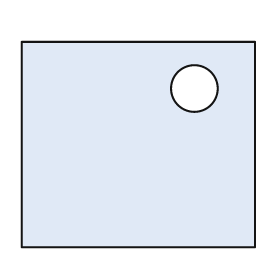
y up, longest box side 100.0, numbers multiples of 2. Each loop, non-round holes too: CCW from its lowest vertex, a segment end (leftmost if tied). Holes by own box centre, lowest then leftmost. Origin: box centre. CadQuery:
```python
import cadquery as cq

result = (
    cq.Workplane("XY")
    .moveTo(-50.0, -44.0)
    .lineTo(50.0, -44.0)
    .lineTo(50.0, 44.0)
    .lineTo(-50.0, 44.0)
    .close()
    .moveTo(24.0, 24.0)
    .circle(10.0)
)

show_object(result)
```